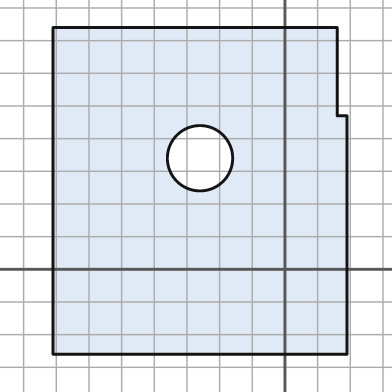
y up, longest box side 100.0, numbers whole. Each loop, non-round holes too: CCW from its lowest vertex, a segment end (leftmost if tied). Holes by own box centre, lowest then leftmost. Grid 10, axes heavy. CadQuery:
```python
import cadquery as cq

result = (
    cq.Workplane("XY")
    .moveTo(-71.0, -26.0)
    .lineTo(19.0, -26.0)
    .lineTo(19.0, 47.0)
    .lineTo(16.0, 47.0)
    .lineTo(16.0, 74.0)
    .lineTo(-71.0, 74.0)
    .close()
    .moveTo(-26.0, 34.0)
    .circle(10.0)
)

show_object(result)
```